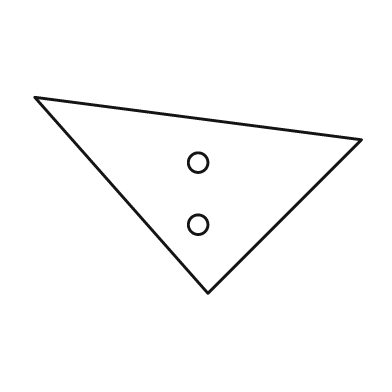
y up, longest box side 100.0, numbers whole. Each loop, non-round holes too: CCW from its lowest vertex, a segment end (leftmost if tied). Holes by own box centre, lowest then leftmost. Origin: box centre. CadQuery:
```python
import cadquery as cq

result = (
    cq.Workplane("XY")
    .moveTo(3.0, -30.0)
    .lineTo(50.0, 17.0)
    .lineTo(-50.0, 30.0)
    .close()
    .moveTo(0.0, -9.0)
    .circle(3.0)
    .moveTo(0.0, 10.0)
    .circle(3.0)
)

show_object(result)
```